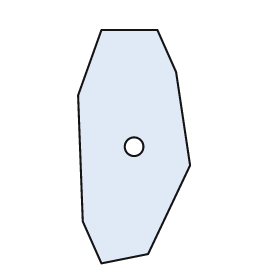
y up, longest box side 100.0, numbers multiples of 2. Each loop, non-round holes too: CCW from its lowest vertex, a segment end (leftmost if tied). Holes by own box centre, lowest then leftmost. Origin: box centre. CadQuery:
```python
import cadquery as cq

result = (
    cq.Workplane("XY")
    .moveTo(-14.0, -50.0)
    .lineTo(6.0, -46.0)
    .lineTo(24.0, -8.0)
    .lineTo(18.0, 32.0)
    .lineTo(10.0, 50.0)
    .lineTo(-14.0, 50.0)
    .lineTo(-24.0, 22.0)
    .lineTo(-22.0, -32.0)
    .close()
    .moveTo(0.0, 0.0)
    .circle(4.0)
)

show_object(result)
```